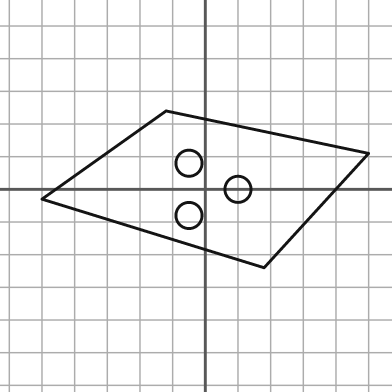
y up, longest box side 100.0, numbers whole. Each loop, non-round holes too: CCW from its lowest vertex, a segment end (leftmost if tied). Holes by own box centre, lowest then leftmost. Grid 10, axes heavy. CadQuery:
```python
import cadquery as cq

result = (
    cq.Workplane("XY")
    .moveTo(18.0, -24.0)
    .lineTo(50.0, 11.0)
    .lineTo(-12.0, 24.0)
    .lineTo(-50.0, -3.0)
    .close()
    .moveTo(-5.0, -8.0)
    .circle(4.0)
    .moveTo(10.0, 0.0)
    .circle(4.0)
    .moveTo(-5.0, 8.0)
    .circle(4.0)
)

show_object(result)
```